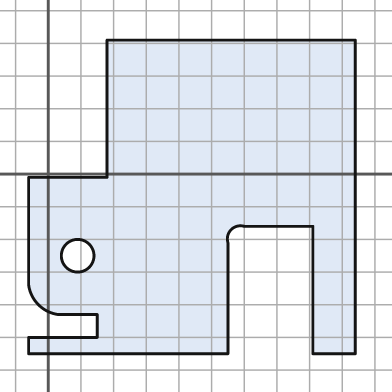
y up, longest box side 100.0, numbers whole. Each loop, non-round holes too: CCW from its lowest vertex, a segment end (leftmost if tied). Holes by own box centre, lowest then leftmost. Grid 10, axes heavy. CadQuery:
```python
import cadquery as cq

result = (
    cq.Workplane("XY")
    .moveTo(-6.0, -55.0)
    .lineTo(55.0, -55.0)
    .lineTo(55.0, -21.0)
    .threePointArc((56.0, -17.0), (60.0, -16.0))
    .lineTo(81.0, -16.0)
    .lineTo(81.0, -55.0)
    .lineTo(94.0, -55.0)
    .lineTo(94.0, 41.0)
    .lineTo(18.0, 41.0)
    .lineTo(18.0, -1.0)
    .lineTo(-6.0, -1.0)
    .lineTo(-6.0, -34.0)
    .threePointArc((-3.0, -40.0), (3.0, -43.0))
    .lineTo(15.0, -43.0)
    .lineTo(15.0, -50.0)
    .lineTo(-6.0, -50.0)
    .close()
    .moveTo(9.0, -25.0)
    .circle(5.0)
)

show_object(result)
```